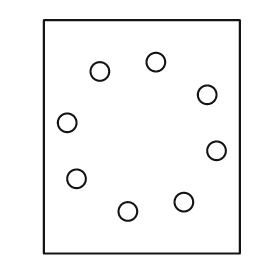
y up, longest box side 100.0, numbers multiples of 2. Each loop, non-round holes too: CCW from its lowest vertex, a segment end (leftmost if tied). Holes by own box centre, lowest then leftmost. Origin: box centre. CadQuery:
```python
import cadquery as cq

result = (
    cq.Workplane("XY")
    .moveTo(-42.0, -50.0)
    .lineTo(42.0, -50.0)
    .lineTo(42.0, 50.0)
    .lineTo(-42.0, 50.0)
    .close()
    .moveTo(-6.0, -32.0)
    .circle(4.0)
    .moveTo(18.0, -28.0)
    .circle(4.0)
    .moveTo(-28.0, -18.0)
    .circle(4.0)
    .moveTo(32.0, -6.0)
    .circle(4.0)
    .moveTo(-32.0, 6.0)
    .circle(4.0)
    .moveTo(28.0, 18.0)
    .circle(4.0)
    .moveTo(-18.0, 28.0)
    .circle(4.0)
    .moveTo(6.0, 32.0)
    .circle(4.0)
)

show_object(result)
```